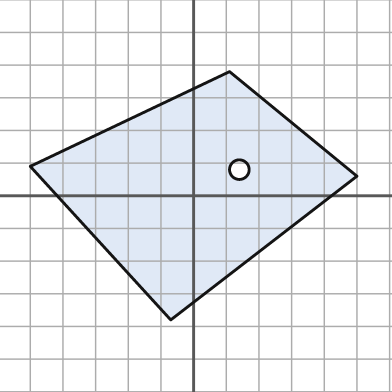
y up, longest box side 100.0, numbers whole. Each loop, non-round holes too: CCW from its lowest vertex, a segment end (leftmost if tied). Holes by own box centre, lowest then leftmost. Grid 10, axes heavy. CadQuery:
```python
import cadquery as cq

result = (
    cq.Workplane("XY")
    .moveTo(-7.0, -38.0)
    .lineTo(50.0, 6.0)
    .lineTo(11.0, 38.0)
    .lineTo(-50.0, 9.0)
    .close()
    .moveTo(14.0, 8.0)
    .circle(3.0)
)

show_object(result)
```